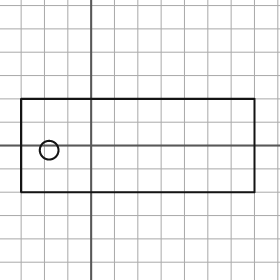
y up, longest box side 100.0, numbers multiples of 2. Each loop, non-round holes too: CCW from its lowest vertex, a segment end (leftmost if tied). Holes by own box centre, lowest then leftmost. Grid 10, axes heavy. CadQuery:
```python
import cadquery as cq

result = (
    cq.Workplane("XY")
    .moveTo(-30.0, -20.0)
    .lineTo(70.0, -20.0)
    .lineTo(70.0, 20.0)
    .lineTo(-30.0, 20.0)
    .close()
    .moveTo(-18.0, -2.0)
    .circle(4.0)
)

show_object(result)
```